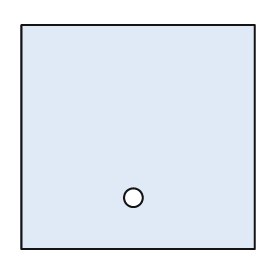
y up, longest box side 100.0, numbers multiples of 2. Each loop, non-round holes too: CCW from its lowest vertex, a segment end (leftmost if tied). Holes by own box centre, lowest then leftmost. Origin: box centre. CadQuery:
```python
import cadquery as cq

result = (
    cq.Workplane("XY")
    .moveTo(-50.0, -48.0)
    .lineTo(50.0, -48.0)
    .lineTo(50.0, 48.0)
    .lineTo(-50.0, 48.0)
    .close()
    .moveTo(-2.0, -26.0)
    .circle(4.0)
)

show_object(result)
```